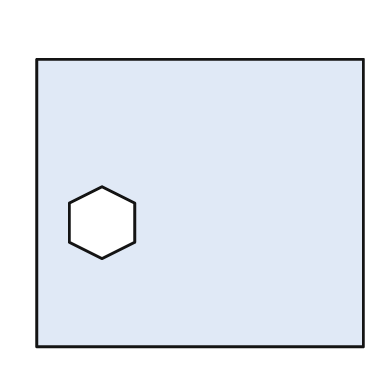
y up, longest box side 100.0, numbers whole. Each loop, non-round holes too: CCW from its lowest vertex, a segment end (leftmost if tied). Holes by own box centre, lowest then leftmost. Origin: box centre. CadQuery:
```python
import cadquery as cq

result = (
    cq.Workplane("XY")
    .moveTo(-50.0, -44.0)
    .lineTo(50.0, -44.0)
    .lineTo(50.0, 44.0)
    .lineTo(-50.0, 44.0)
    .close()
    .moveTo(-30.0, -17.0)
    .lineTo(-20.0, -12.0)
    .lineTo(-20.0, 0.0)
    .lineTo(-30.0, 5.0)
    .lineTo(-40.0, 0.0)
    .lineTo(-40.0, -12.0)
    .close()
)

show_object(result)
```